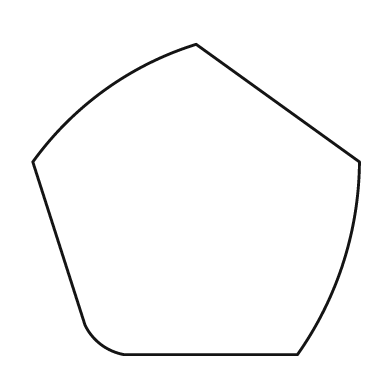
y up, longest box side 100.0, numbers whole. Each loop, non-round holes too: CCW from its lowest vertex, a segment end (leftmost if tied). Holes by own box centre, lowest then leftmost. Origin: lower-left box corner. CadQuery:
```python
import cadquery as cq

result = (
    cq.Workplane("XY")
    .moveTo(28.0, 0.0)
    .lineTo(81.0, 0.0)
    .threePointArc((95.0, 28.0), (100.0, 59.0))
    .lineTo(50.0, 95.0)
    .threePointArc((22.0, 81.0), (0.0, 59.0))
    .lineTo(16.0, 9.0)
    .threePointArc((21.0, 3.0), (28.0, 0.0))
    .close()
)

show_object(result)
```